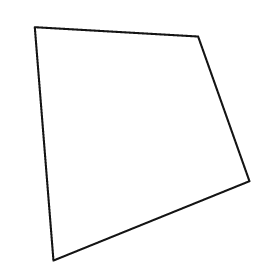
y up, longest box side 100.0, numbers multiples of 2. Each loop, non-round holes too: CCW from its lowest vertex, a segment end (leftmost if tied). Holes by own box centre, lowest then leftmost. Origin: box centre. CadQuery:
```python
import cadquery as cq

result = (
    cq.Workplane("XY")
    .moveTo(-38.0, -50.0)
    .lineTo(46.0, -16.0)
    .lineTo(24.0, 46.0)
    .lineTo(-46.0, 50.0)
    .close()
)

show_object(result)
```